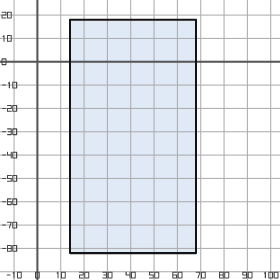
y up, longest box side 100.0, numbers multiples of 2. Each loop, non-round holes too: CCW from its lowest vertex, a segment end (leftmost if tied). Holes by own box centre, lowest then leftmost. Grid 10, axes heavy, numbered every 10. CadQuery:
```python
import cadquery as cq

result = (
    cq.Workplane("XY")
    .moveTo(14.0, -82.0)
    .lineTo(68.0, -82.0)
    .lineTo(68.0, 18.0)
    .lineTo(14.0, 18.0)
    .close()
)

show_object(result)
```